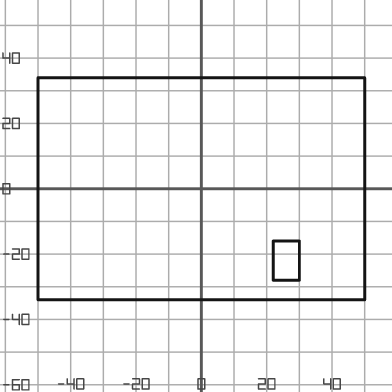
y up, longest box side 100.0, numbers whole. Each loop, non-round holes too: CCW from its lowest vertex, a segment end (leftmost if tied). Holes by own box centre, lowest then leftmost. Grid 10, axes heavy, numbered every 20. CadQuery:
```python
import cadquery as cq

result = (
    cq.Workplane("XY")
    .moveTo(-50.0, -34.0)
    .lineTo(50.0, -34.0)
    .lineTo(50.0, 34.0)
    .lineTo(-50.0, 34.0)
    .close()
    .moveTo(22.0, -28.0)
    .lineTo(30.0, -28.0)
    .lineTo(30.0, -16.0)
    .lineTo(22.0, -16.0)
    .close()
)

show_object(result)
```